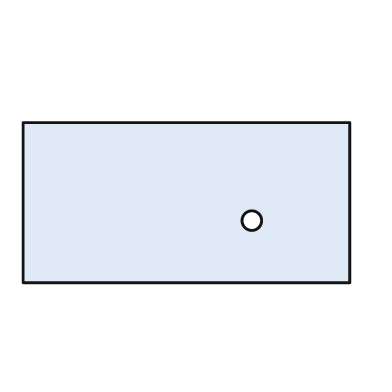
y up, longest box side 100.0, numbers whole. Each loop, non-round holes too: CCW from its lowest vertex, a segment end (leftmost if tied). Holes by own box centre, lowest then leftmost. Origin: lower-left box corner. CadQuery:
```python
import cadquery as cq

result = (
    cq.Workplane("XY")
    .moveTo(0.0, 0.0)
    .lineTo(100.0, 0.0)
    .lineTo(100.0, 49.0)
    .lineTo(0.0, 49.0)
    .close()
    .moveTo(70.0, 19.0)
    .circle(3.0)
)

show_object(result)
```